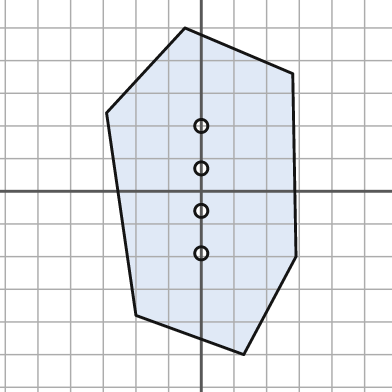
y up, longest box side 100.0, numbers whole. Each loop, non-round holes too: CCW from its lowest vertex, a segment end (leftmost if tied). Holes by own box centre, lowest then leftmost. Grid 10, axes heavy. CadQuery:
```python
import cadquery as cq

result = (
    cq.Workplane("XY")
    .moveTo(13.0, -50.0)
    .lineTo(29.0, -20.0)
    .lineTo(28.0, 36.0)
    .lineTo(-5.0, 50.0)
    .lineTo(-29.0, 24.0)
    .lineTo(-20.0, -38.0)
    .close()
    .moveTo(0.0, -19.0)
    .circle(2.0)
    .moveTo(0.0, -6.0)
    .circle(2.0)
    .moveTo(0.0, 7.0)
    .circle(2.0)
    .moveTo(0.0, 20.0)
    .circle(2.0)
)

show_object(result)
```